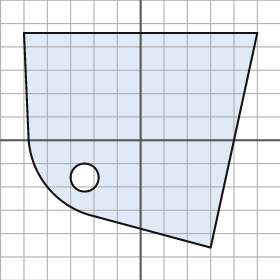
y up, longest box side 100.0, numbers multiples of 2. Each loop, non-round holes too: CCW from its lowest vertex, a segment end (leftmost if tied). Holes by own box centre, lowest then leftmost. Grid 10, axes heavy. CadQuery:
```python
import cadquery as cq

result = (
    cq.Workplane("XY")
    .moveTo(30.0, -46.0)
    .lineTo(50.0, 46.0)
    .lineTo(-50.0, 46.0)
    .lineTo(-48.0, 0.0)
    .threePointArc((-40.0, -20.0), (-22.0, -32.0))
    .close()
    .moveTo(-24.0, -16.0)
    .circle(6.0)
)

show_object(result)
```